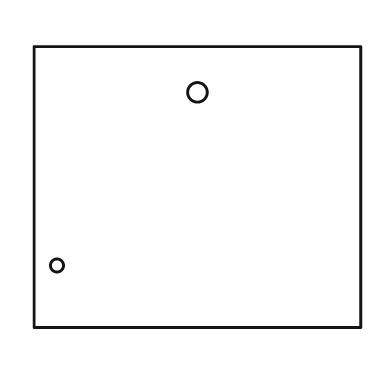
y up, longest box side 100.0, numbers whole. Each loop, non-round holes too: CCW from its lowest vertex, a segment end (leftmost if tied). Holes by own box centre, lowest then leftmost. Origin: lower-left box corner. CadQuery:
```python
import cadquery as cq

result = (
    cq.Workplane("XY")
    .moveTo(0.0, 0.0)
    .lineTo(100.0, 0.0)
    .lineTo(100.0, 86.0)
    .lineTo(0.0, 86.0)
    .close()
    .moveTo(7.0, 19.0)
    .circle(2.0)
    .moveTo(50.0, 72.0)
    .circle(3.0)
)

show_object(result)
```